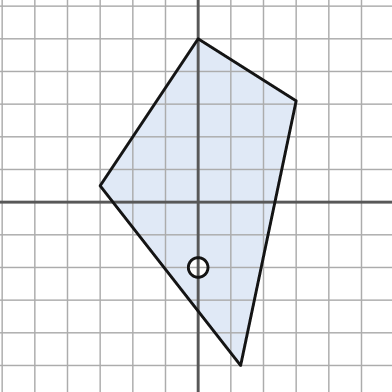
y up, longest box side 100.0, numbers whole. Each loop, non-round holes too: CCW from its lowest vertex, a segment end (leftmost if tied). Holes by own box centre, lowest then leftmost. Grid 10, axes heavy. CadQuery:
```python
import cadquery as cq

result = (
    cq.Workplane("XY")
    .moveTo(13.0, -50.0)
    .lineTo(30.0, 31.0)
    .lineTo(0.0, 50.0)
    .lineTo(-30.0, 5.0)
    .close()
    .moveTo(0.0, -20.0)
    .circle(3.0)
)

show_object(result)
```